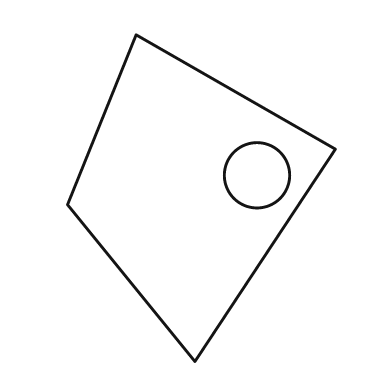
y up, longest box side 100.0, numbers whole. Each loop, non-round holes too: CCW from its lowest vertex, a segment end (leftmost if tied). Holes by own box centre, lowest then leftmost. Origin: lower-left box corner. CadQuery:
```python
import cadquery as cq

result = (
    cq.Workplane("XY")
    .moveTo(39.0, 0.0)
    .lineTo(82.0, 65.0)
    .lineTo(21.0, 100.0)
    .lineTo(0.0, 48.0)
    .close()
    .moveTo(58.0, 57.0)
    .circle(10.0)
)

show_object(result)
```